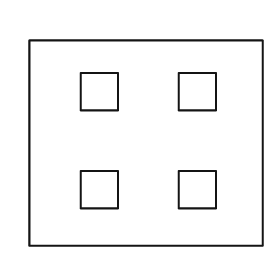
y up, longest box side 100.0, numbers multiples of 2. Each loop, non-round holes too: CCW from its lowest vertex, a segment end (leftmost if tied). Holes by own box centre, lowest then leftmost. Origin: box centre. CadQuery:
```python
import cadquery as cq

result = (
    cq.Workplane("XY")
    .moveTo(-50.0, -44.0)
    .lineTo(50.0, -44.0)
    .lineTo(50.0, 44.0)
    .lineTo(-50.0, 44.0)
    .close()
    .moveTo(-28.0, -28.0)
    .lineTo(-12.0, -28.0)
    .lineTo(-12.0, -12.0)
    .lineTo(-28.0, -12.0)
    .close()
    .moveTo(14.0, -28.0)
    .lineTo(30.0, -28.0)
    .lineTo(30.0, -12.0)
    .lineTo(14.0, -12.0)
    .close()
    .moveTo(-28.0, 14.0)
    .lineTo(-12.0, 14.0)
    .lineTo(-12.0, 30.0)
    .lineTo(-28.0, 30.0)
    .close()
    .moveTo(14.0, 14.0)
    .lineTo(30.0, 14.0)
    .lineTo(30.0, 30.0)
    .lineTo(14.0, 30.0)
    .close()
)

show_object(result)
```